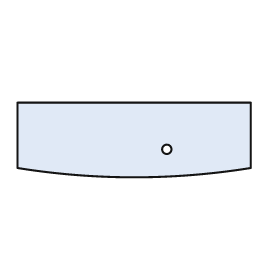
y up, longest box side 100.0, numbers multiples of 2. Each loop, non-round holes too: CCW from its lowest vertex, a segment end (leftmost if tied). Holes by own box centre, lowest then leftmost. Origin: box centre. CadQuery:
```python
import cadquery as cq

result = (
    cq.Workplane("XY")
    .moveTo(-50.0, -12.0)
    .threePointArc((0.0, -16.0), (50.0, -12.0))
    .lineTo(50.0, 16.0)
    .lineTo(-50.0, 16.0)
    .close()
    .moveTo(14.0, -4.0)
    .circle(2.0)
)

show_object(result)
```